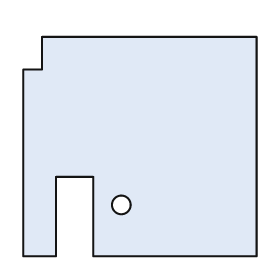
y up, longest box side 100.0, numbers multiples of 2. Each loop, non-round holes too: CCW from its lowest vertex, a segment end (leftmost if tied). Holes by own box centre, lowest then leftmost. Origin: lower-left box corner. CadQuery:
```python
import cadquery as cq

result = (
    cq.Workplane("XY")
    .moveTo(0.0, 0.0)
    .lineTo(14.0, 0.0)
    .lineTo(14.0, 34.0)
    .lineTo(30.0, 34.0)
    .lineTo(30.0, 0.0)
    .lineTo(100.0, 0.0)
    .lineTo(100.0, 94.0)
    .lineTo(8.0, 94.0)
    .lineTo(8.0, 80.0)
    .lineTo(0.0, 80.0)
    .close()
    .moveTo(42.0, 22.0)
    .circle(4.0)
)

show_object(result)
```